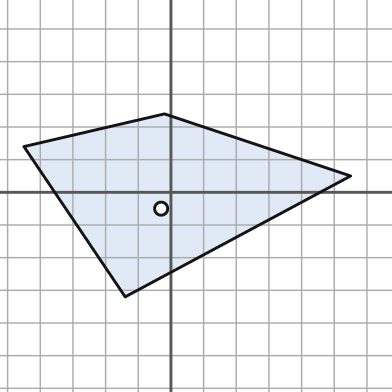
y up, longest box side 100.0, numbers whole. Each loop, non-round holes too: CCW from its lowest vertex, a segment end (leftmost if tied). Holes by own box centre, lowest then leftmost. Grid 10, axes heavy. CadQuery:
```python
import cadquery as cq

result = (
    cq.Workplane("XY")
    .moveTo(-14.0, -32.0)
    .lineTo(55.0, 5.0)
    .lineTo(-2.0, 24.0)
    .lineTo(-45.0, 14.0)
    .close()
    .moveTo(-3.0, -5.0)
    .circle(2.0)
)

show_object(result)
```